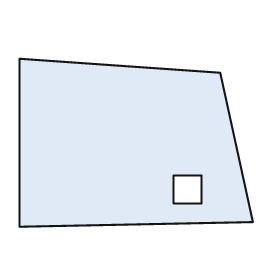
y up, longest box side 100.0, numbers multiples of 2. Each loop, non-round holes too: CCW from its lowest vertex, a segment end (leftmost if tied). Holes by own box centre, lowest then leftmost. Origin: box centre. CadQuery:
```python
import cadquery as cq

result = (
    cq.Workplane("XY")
    .moveTo(-50.0, -36.0)
    .lineTo(50.0, -34.0)
    .lineTo(36.0, 30.0)
    .lineTo(-50.0, 36.0)
    .close()
    .moveTo(16.0, -26.0)
    .lineTo(28.0, -26.0)
    .lineTo(28.0, -14.0)
    .lineTo(16.0, -14.0)
    .close()
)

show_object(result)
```